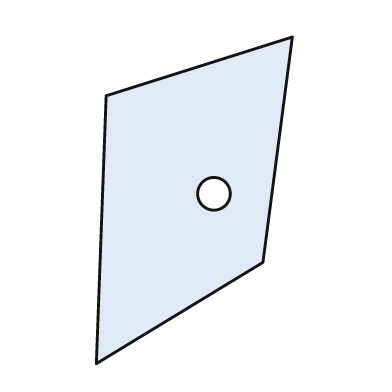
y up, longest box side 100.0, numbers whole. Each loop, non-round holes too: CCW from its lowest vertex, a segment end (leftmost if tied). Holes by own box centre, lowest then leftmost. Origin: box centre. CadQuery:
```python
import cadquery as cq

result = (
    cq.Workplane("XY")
    .moveTo(-30.0, -50.0)
    .lineTo(21.0, -19.0)
    .lineTo(30.0, 50.0)
    .lineTo(-27.0, 32.0)
    .close()
    .moveTo(6.0, 2.0)
    .circle(5.0)
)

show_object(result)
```